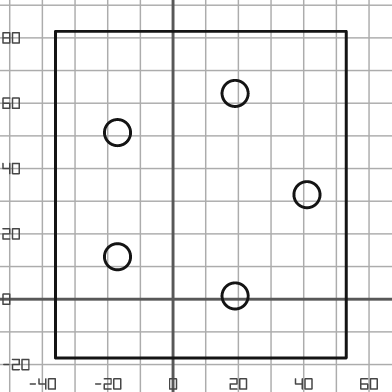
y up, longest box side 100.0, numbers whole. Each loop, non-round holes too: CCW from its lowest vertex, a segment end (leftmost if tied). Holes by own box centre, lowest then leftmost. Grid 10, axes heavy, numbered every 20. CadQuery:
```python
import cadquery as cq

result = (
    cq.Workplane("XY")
    .moveTo(-36.0, -18.0)
    .lineTo(53.0, -18.0)
    .lineTo(53.0, 82.0)
    .lineTo(-36.0, 82.0)
    .close()
    .moveTo(19.0, 1.0)
    .circle(4.0)
    .moveTo(-17.0, 13.0)
    .circle(4.0)
    .moveTo(41.0, 32.0)
    .circle(4.0)
    .moveTo(-17.0, 51.0)
    .circle(4.0)
    .moveTo(19.0, 63.0)
    .circle(4.0)
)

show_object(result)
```